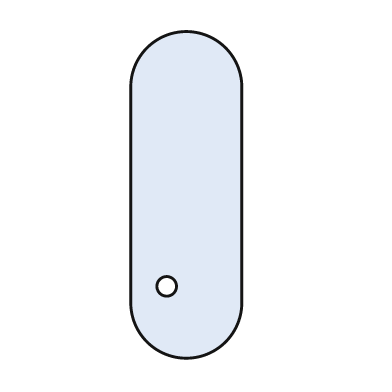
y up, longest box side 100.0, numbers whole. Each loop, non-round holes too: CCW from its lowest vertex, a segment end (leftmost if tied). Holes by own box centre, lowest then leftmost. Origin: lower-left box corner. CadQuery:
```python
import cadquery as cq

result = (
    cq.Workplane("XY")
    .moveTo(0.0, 17.0)
    .threePointArc((17.0, 0.0), (34.0, 17.0))
    .lineTo(34.0, 83.0)
    .threePointArc((17.0, 100.0), (0.0, 83.0))
    .close()
    .moveTo(11.0, 22.0)
    .circle(3.0)
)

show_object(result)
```